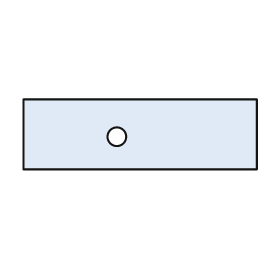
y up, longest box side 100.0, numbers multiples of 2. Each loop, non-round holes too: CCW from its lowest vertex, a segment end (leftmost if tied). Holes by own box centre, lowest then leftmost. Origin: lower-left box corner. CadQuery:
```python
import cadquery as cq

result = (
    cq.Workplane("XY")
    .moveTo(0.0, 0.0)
    .lineTo(100.0, 0.0)
    .lineTo(100.0, 30.0)
    .lineTo(0.0, 30.0)
    .close()
    .moveTo(40.0, 14.0)
    .circle(4.0)
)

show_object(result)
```